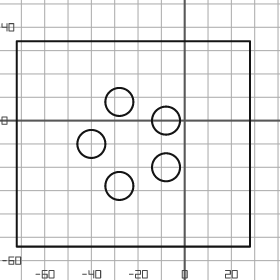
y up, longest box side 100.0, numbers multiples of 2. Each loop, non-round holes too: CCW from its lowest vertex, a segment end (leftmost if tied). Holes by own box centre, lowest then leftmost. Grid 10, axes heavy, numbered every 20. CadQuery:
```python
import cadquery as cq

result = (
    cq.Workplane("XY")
    .moveTo(-72.0, -54.0)
    .lineTo(28.0, -54.0)
    .lineTo(28.0, 34.0)
    .lineTo(-72.0, 34.0)
    .close()
    .moveTo(-28.0, -28.0)
    .circle(6.0)
    .moveTo(-8.0, -20.0)
    .circle(6.0)
    .moveTo(-40.0, -10.0)
    .circle(6.0)
    .moveTo(-8.0, 0.0)
    .circle(6.0)
    .moveTo(-28.0, 8.0)
    .circle(6.0)
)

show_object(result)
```